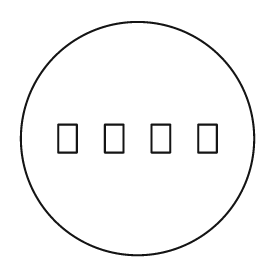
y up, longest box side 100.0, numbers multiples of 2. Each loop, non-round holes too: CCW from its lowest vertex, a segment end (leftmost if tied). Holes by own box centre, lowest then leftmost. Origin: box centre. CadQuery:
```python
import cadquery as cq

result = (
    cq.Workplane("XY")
    .moveTo(0.0, 0.0)
    .circle(50.0)
    .moveTo(-34.0, -6.0)
    .lineTo(-26.0, -6.0)
    .lineTo(-26.0, 6.0)
    .lineTo(-34.0, 6.0)
    .close()
    .moveTo(-14.0, -6.0)
    .lineTo(-6.0, -6.0)
    .lineTo(-6.0, 6.0)
    .lineTo(-14.0, 6.0)
    .close()
    .moveTo(6.0, -6.0)
    .lineTo(14.0, -6.0)
    .lineTo(14.0, 6.0)
    .lineTo(6.0, 6.0)
    .close()
    .moveTo(26.0, -6.0)
    .lineTo(34.0, -6.0)
    .lineTo(34.0, 6.0)
    .lineTo(26.0, 6.0)
    .close()
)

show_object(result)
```